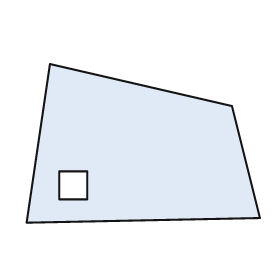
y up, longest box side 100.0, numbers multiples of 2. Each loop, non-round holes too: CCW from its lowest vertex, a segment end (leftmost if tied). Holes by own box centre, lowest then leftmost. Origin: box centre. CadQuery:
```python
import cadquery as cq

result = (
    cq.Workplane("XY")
    .moveTo(-50.0, -34.0)
    .lineTo(50.0, -32.0)
    .lineTo(38.0, 16.0)
    .lineTo(-40.0, 34.0)
    .close()
    .moveTo(-36.0, -24.0)
    .lineTo(-24.0, -24.0)
    .lineTo(-24.0, -12.0)
    .lineTo(-36.0, -12.0)
    .close()
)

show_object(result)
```